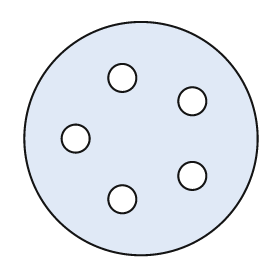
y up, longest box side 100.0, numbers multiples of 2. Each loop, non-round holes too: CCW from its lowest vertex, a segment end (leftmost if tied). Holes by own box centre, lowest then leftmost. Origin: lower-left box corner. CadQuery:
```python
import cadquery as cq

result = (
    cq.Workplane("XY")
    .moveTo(50.0, 50.0)
    .circle(50.0)
    .moveTo(42.0, 24.0)
    .circle(6.0)
    .moveTo(72.0, 34.0)
    .circle(6.0)
    .moveTo(22.0, 50.0)
    .circle(6.0)
    .moveTo(72.0, 66.0)
    .circle(6.0)
    .moveTo(42.0, 76.0)
    .circle(6.0)
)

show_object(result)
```